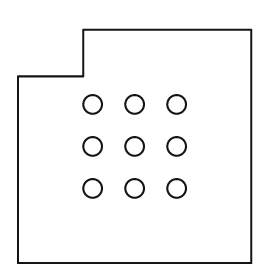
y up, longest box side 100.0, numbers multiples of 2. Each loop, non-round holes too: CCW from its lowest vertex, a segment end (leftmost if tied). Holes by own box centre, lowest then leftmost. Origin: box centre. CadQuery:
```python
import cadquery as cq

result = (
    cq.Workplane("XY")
    .moveTo(-50.0, -50.0)
    .lineTo(50.0, -50.0)
    .lineTo(50.0, 50.0)
    .lineTo(-22.0, 50.0)
    .lineTo(-22.0, 30.0)
    .lineTo(-50.0, 30.0)
    .close()
    .moveTo(-18.0, -18.0)
    .circle(4.0)
    .moveTo(0.0, -18.0)
    .circle(4.0)
    .moveTo(18.0, -18.0)
    .circle(4.0)
    .moveTo(-18.0, 0.0)
    .circle(4.0)
    .moveTo(0.0, 0.0)
    .circle(4.0)
    .moveTo(18.0, 0.0)
    .circle(4.0)
    .moveTo(-18.0, 18.0)
    .circle(4.0)
    .moveTo(0.0, 18.0)
    .circle(4.0)
    .moveTo(18.0, 18.0)
    .circle(4.0)
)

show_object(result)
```